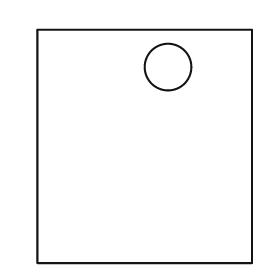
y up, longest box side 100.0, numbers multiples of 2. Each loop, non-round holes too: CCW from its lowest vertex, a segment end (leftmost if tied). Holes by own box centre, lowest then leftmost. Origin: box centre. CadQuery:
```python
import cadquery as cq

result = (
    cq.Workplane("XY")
    .moveTo(-46.0, -50.0)
    .lineTo(46.0, -50.0)
    .lineTo(46.0, 50.0)
    .lineTo(-46.0, 50.0)
    .close()
    .moveTo(10.0, 34.0)
    .circle(10.0)
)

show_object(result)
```